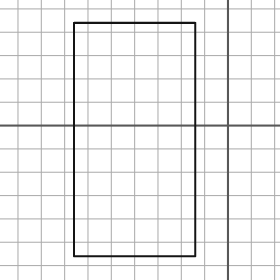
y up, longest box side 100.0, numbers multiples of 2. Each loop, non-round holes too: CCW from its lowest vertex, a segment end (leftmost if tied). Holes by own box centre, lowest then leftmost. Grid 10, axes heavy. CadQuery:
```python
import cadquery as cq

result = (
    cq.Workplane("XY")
    .moveTo(-66.0, -56.0)
    .lineTo(-14.0, -56.0)
    .lineTo(-14.0, 44.0)
    .lineTo(-66.0, 44.0)
    .close()
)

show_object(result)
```